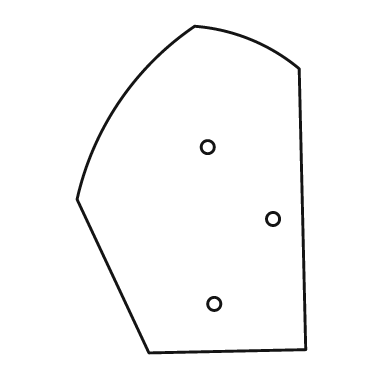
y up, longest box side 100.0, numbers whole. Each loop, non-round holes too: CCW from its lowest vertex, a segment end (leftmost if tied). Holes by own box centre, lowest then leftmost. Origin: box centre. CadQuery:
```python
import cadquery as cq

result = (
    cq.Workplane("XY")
    .moveTo(-13.0, -50.0)
    .lineTo(35.0, -49.0)
    .lineTo(33.0, 37.0)
    .threePointArc((18.0, 46.0), (1.0, 50.0))
    .threePointArc((-22.0, 27.0), (-35.0, -3.0))
    .close()
    .moveTo(7.0, -35.0)
    .circle(2.0)
    .moveTo(25.0, -9.0)
    .circle(2.0)
    .moveTo(5.0, 13.0)
    .circle(2.0)
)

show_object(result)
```